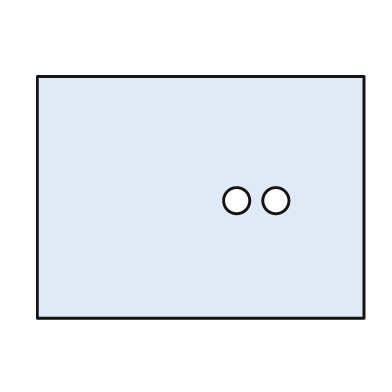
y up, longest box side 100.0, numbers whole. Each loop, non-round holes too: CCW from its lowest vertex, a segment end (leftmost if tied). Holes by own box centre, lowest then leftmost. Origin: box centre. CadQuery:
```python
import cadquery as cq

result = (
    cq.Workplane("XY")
    .moveTo(-50.0, -37.0)
    .lineTo(50.0, -37.0)
    .lineTo(50.0, 37.0)
    .lineTo(-50.0, 37.0)
    .close()
    .moveTo(11.0, -1.0)
    .circle(4.0)
    .moveTo(23.0, -1.0)
    .circle(4.0)
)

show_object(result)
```